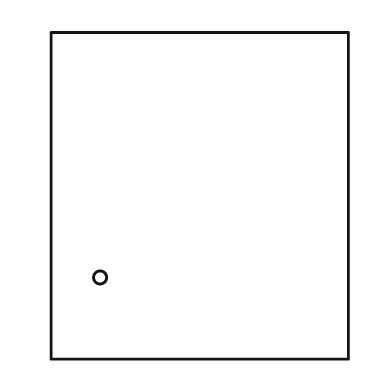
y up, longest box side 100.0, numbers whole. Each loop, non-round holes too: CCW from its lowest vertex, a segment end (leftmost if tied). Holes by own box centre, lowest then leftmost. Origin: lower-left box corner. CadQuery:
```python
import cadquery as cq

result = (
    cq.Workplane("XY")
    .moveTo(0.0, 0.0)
    .lineTo(91.0, 0.0)
    .lineTo(91.0, 100.0)
    .lineTo(0.0, 100.0)
    .close()
    .moveTo(15.0, 25.0)
    .circle(2.0)
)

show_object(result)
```